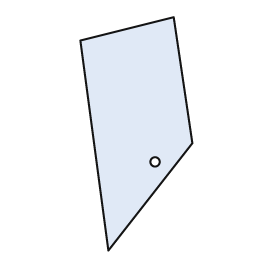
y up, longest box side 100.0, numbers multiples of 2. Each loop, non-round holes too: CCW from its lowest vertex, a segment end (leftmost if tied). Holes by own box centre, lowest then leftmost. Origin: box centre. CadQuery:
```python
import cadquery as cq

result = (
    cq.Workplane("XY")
    .moveTo(-12.0, -50.0)
    .lineTo(24.0, -4.0)
    .lineTo(16.0, 50.0)
    .lineTo(-24.0, 40.0)
    .close()
    .moveTo(8.0, -12.0)
    .circle(2.0)
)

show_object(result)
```